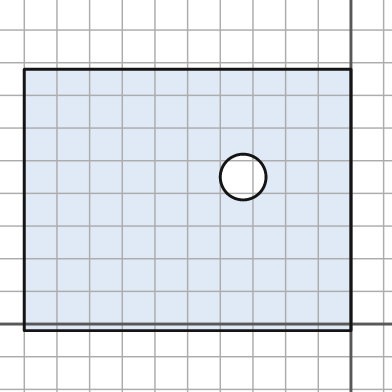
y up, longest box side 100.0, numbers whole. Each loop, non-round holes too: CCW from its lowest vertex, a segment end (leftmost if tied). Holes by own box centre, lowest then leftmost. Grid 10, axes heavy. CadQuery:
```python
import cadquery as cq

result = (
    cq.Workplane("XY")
    .moveTo(-100.0, -2.0)
    .lineTo(0.0, -2.0)
    .lineTo(0.0, 78.0)
    .lineTo(-100.0, 78.0)
    .close()
    .moveTo(-33.0, 45.0)
    .circle(7.0)
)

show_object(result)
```